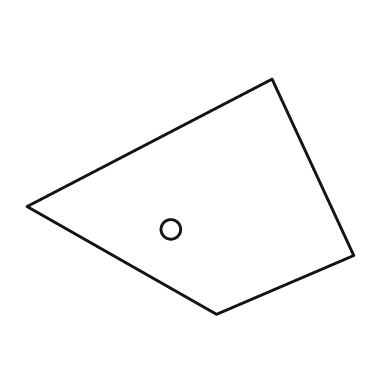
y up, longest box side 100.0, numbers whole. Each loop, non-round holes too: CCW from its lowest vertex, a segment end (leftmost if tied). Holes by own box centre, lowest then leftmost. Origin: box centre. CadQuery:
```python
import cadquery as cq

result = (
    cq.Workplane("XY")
    .moveTo(8.0, -36.0)
    .lineTo(50.0, -18.0)
    .lineTo(25.0, 36.0)
    .lineTo(-50.0, -3.0)
    .close()
    .moveTo(-6.0, -10.0)
    .circle(3.0)
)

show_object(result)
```